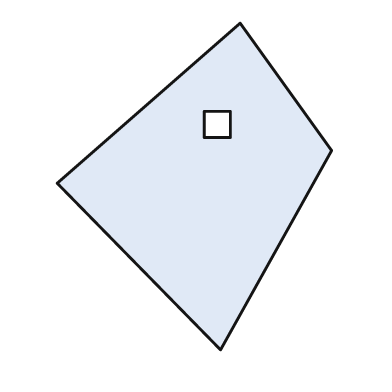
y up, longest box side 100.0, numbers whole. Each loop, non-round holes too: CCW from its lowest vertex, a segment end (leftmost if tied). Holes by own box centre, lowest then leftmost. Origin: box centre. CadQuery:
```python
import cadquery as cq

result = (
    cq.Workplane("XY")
    .moveTo(8.0, -50.0)
    .lineTo(42.0, 11.0)
    .lineTo(14.0, 50.0)
    .lineTo(-42.0, 1.0)
    .close()
    .moveTo(3.0, 15.0)
    .lineTo(11.0, 15.0)
    .lineTo(11.0, 23.0)
    .lineTo(3.0, 23.0)
    .close()
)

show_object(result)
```